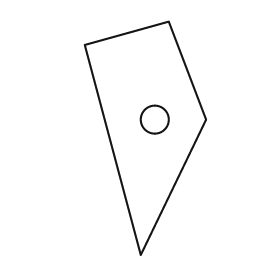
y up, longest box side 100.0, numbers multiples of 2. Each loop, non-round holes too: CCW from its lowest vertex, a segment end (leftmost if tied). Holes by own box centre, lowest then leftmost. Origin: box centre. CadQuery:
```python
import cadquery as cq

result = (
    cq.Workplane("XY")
    .moveTo(-2.0, -50.0)
    .lineTo(26.0, 8.0)
    .lineTo(10.0, 50.0)
    .lineTo(-26.0, 40.0)
    .close()
    .moveTo(4.0, 8.0)
    .circle(6.0)
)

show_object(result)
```